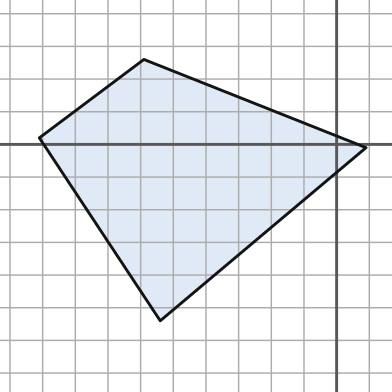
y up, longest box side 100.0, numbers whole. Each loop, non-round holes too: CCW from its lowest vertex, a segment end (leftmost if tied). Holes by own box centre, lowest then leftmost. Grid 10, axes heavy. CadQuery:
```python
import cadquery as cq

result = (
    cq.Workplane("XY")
    .moveTo(-54.0, -54.0)
    .lineTo(9.0, -1.0)
    .lineTo(-59.0, 26.0)
    .lineTo(-91.0, 2.0)
    .close()
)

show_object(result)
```